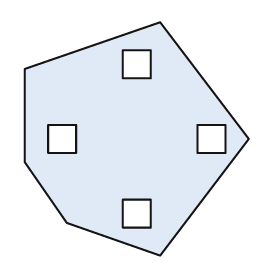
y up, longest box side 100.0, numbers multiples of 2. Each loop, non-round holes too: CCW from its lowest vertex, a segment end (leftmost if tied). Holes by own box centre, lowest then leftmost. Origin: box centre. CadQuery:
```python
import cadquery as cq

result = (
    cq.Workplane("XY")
    .moveTo(10.0, -50.0)
    .lineTo(48.0, 0.0)
    .lineTo(10.0, 50.0)
    .lineTo(-48.0, 30.0)
    .lineTo(-48.0, -10.0)
    .lineTo(-30.0, -36.0)
    .close()
    .moveTo(-6.0, -38.0)
    .lineTo(6.0, -38.0)
    .lineTo(6.0, -26.0)
    .lineTo(-6.0, -26.0)
    .close()
    .moveTo(-38.0, -6.0)
    .lineTo(-26.0, -6.0)
    .lineTo(-26.0, 6.0)
    .lineTo(-38.0, 6.0)
    .close()
    .moveTo(26.0, -6.0)
    .lineTo(38.0, -6.0)
    .lineTo(38.0, 6.0)
    .lineTo(26.0, 6.0)
    .close()
    .moveTo(-6.0, 26.0)
    .lineTo(6.0, 26.0)
    .lineTo(6.0, 38.0)
    .lineTo(-6.0, 38.0)
    .close()
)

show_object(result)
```